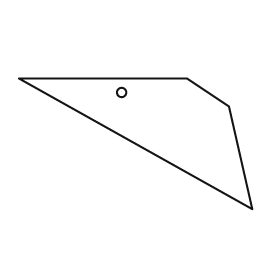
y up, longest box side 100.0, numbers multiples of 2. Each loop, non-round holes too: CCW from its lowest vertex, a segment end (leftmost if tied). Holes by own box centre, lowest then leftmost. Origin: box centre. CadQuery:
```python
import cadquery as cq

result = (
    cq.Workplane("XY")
    .moveTo(50.0, -28.0)
    .lineTo(40.0, 16.0)
    .lineTo(22.0, 28.0)
    .lineTo(-50.0, 28.0)
    .close()
    .moveTo(-6.0, 22.0)
    .circle(2.0)
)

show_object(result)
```